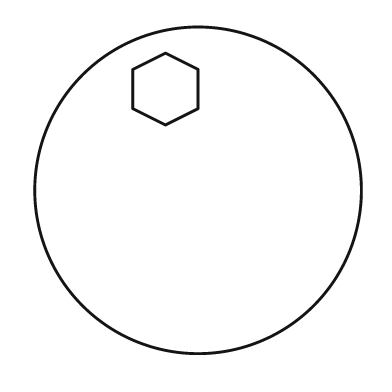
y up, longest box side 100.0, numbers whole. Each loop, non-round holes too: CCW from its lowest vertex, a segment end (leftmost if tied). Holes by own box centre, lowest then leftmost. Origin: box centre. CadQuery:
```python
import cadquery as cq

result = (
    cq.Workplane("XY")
    .moveTo(0.0, 0.0)
    .circle(50.0)
    .moveTo(-10.0, 20.0)
    .lineTo(0.0, 25.0)
    .lineTo(0.0, 37.0)
    .lineTo(-10.0, 42.0)
    .lineTo(-20.0, 37.0)
    .lineTo(-20.0, 25.0)
    .close()
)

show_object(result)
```